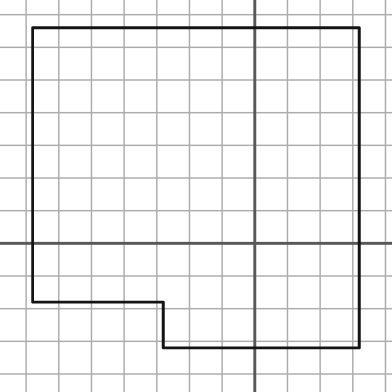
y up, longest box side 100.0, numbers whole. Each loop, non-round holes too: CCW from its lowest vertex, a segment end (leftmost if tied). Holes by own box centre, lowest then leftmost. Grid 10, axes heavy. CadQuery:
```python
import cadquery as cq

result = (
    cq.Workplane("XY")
    .moveTo(-28.0, -32.0)
    .lineTo(32.0, -32.0)
    .lineTo(32.0, 66.0)
    .lineTo(-68.0, 66.0)
    .lineTo(-68.0, -18.0)
    .lineTo(-28.0, -18.0)
    .close()
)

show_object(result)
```